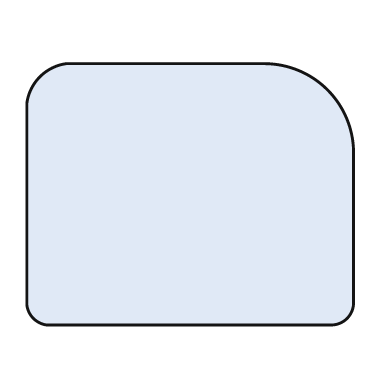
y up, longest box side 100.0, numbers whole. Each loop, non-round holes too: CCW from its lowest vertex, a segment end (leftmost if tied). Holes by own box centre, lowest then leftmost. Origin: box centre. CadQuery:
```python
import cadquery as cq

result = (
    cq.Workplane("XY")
    .moveTo(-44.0, -40.0)
    .lineTo(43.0, -40.0)
    .threePointArc((48.0, -38.0), (50.0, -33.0))
    .lineTo(50.0, 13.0)
    .threePointArc((42.0, 32.0), (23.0, 40.0))
    .lineTo(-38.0, 40.0)
    .threePointArc((-46.0, 36.0), (-50.0, 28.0))
    .lineTo(-50.0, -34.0)
    .threePointArc((-48.0, -38.0), (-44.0, -40.0))
    .close()
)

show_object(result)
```